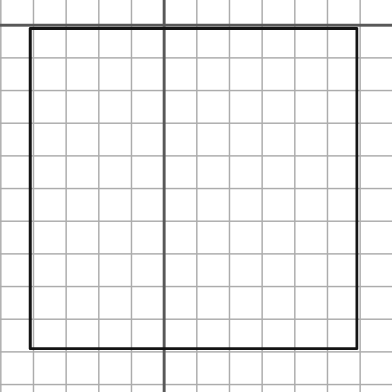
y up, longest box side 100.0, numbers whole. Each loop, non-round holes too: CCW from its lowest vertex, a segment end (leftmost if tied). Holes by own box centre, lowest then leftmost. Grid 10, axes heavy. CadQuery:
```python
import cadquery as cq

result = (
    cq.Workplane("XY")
    .moveTo(-41.0, -99.0)
    .lineTo(59.0, -99.0)
    .lineTo(59.0, -1.0)
    .lineTo(-41.0, -1.0)
    .close()
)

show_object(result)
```